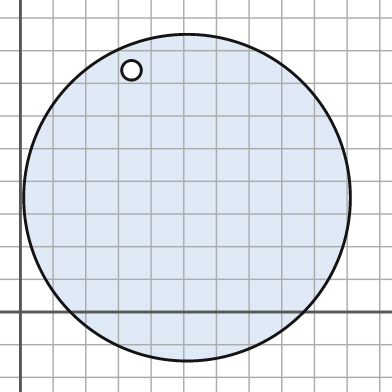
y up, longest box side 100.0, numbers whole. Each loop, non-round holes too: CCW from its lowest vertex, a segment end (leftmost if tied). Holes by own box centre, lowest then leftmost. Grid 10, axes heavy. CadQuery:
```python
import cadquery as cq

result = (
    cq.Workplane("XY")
    .moveTo(51.0, 35.0)
    .circle(50.0)
    .moveTo(34.0, 74.0)
    .circle(3.0)
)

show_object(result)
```